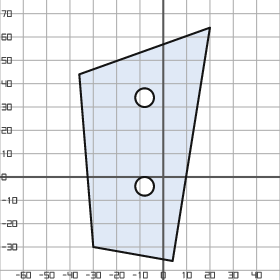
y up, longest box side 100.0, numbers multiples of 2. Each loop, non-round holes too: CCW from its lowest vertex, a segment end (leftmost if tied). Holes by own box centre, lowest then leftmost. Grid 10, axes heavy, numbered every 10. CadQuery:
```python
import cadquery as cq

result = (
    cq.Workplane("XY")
    .moveTo(4.0, -36.0)
    .lineTo(20.0, 64.0)
    .lineTo(-36.0, 44.0)
    .lineTo(-30.0, -30.0)
    .close()
    .moveTo(-8.0, -4.0)
    .circle(4.0)
    .moveTo(-8.0, 34.0)
    .circle(4.0)
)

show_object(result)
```